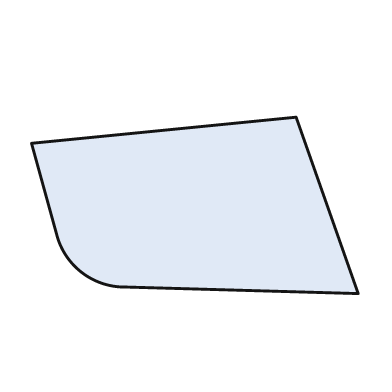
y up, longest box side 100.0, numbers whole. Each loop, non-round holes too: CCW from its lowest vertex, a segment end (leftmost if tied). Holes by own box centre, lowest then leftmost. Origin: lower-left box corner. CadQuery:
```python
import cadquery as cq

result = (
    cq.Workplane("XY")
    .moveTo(100.0, 0.0)
    .lineTo(81.0, 54.0)
    .lineTo(0.0, 46.0)
    .lineTo(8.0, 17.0)
    .threePointArc((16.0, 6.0), (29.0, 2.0))
    .close()
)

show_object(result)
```